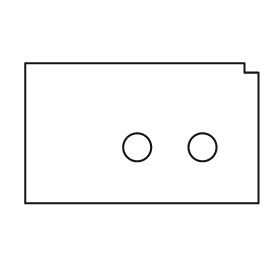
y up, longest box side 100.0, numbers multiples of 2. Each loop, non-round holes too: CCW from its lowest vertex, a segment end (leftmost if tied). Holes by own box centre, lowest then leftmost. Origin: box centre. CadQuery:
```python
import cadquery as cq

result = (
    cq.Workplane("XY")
    .moveTo(-50.0, -30.0)
    .lineTo(50.0, -30.0)
    .lineTo(50.0, 26.0)
    .lineTo(44.0, 26.0)
    .lineTo(44.0, 30.0)
    .lineTo(-50.0, 30.0)
    .close()
    .moveTo(-2.0, -6.0)
    .circle(6.0)
    .moveTo(26.0, -6.0)
    .circle(6.0)
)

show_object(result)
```